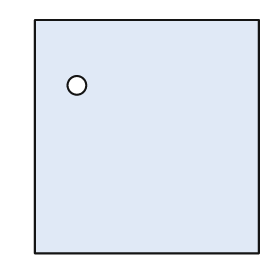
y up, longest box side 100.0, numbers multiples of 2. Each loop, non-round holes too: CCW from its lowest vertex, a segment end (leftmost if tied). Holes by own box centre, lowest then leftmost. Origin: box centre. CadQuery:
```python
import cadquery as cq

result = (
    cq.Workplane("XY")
    .moveTo(-48.0, -50.0)
    .lineTo(48.0, -50.0)
    .lineTo(48.0, 50.0)
    .lineTo(-48.0, 50.0)
    .close()
    .moveTo(-30.0, 22.0)
    .circle(4.0)
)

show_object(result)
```